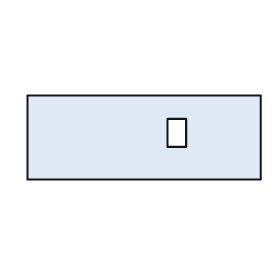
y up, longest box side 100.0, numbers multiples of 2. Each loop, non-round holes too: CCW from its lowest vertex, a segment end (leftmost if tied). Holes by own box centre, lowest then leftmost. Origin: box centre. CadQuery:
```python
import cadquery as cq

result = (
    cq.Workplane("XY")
    .moveTo(-50.0, -18.0)
    .lineTo(50.0, -18.0)
    .lineTo(50.0, 18.0)
    .lineTo(-50.0, 18.0)
    .close()
    .moveTo(10.0, -4.0)
    .lineTo(18.0, -4.0)
    .lineTo(18.0, 8.0)
    .lineTo(10.0, 8.0)
    .close()
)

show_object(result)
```